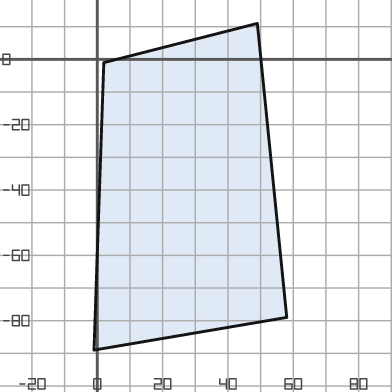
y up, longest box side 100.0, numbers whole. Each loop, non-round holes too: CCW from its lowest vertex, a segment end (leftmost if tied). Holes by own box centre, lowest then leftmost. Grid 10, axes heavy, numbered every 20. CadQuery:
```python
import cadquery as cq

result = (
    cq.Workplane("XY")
    .moveTo(-1.0, -89.0)
    .lineTo(58.0, -79.0)
    .lineTo(49.0, 11.0)
    .lineTo(2.0, -1.0)
    .close()
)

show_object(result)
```